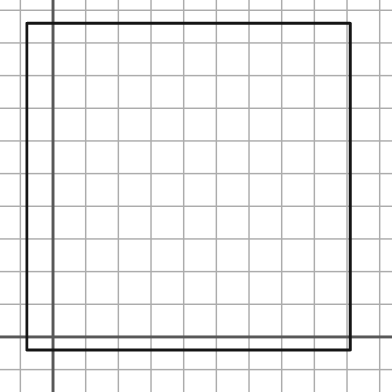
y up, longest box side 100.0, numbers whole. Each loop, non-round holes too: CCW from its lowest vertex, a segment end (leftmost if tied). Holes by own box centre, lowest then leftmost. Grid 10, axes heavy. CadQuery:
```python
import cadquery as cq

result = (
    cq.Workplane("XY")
    .moveTo(-8.0, -4.0)
    .lineTo(91.0, -4.0)
    .lineTo(91.0, 96.0)
    .lineTo(-8.0, 96.0)
    .close()
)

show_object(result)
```